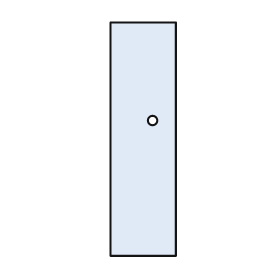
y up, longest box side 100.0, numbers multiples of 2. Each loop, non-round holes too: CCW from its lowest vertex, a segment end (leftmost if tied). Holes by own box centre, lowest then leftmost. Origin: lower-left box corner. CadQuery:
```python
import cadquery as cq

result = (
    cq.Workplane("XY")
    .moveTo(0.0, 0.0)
    .lineTo(28.0, 0.0)
    .lineTo(28.0, 100.0)
    .lineTo(0.0, 100.0)
    .close()
    .moveTo(18.0, 58.0)
    .circle(2.0)
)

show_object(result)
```